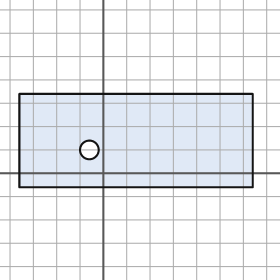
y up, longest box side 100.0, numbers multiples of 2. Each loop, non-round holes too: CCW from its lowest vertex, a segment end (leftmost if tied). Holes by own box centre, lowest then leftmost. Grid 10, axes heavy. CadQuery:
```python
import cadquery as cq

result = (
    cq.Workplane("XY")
    .moveTo(-36.0, -6.0)
    .lineTo(64.0, -6.0)
    .lineTo(64.0, 34.0)
    .lineTo(-36.0, 34.0)
    .close()
    .moveTo(-6.0, 10.0)
    .circle(4.0)
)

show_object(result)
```